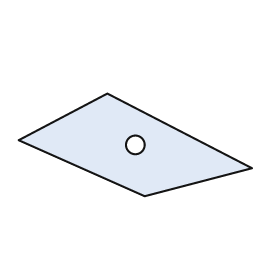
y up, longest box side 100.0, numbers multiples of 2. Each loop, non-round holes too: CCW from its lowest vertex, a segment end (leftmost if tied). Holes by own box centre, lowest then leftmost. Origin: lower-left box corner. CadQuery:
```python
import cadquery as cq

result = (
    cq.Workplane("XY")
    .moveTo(54.0, 0.0)
    .lineTo(100.0, 12.0)
    .lineTo(38.0, 44.0)
    .lineTo(0.0, 24.0)
    .close()
    .moveTo(50.0, 22.0)
    .circle(4.0)
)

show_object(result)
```